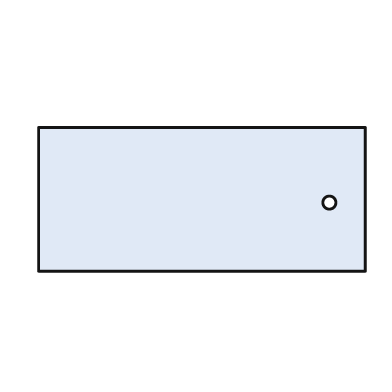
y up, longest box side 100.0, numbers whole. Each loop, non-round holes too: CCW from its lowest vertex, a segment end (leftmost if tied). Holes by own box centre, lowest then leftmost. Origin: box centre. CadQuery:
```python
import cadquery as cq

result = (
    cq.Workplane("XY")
    .moveTo(-50.0, -22.0)
    .lineTo(50.0, -22.0)
    .lineTo(50.0, 22.0)
    .lineTo(-50.0, 22.0)
    .close()
    .moveTo(39.0, -1.0)
    .circle(2.0)
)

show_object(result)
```